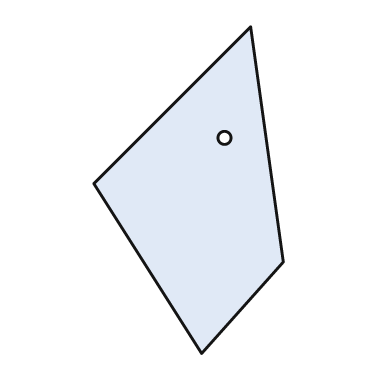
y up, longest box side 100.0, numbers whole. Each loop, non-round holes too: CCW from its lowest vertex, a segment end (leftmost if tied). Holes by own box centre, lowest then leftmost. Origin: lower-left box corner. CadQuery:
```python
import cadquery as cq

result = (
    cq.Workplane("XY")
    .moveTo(33.0, 0.0)
    .lineTo(58.0, 28.0)
    .lineTo(48.0, 100.0)
    .lineTo(0.0, 52.0)
    .close()
    .moveTo(40.0, 66.0)
    .circle(2.0)
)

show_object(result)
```